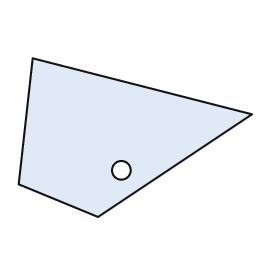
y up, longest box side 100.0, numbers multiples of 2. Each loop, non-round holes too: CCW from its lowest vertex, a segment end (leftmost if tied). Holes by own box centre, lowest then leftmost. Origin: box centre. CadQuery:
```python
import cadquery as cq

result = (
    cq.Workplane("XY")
    .moveTo(-16.0, -34.0)
    .lineTo(50.0, 10.0)
    .lineTo(-44.0, 34.0)
    .lineTo(-50.0, -20.0)
    .close()
    .moveTo(-6.0, -14.0)
    .circle(4.0)
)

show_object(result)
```